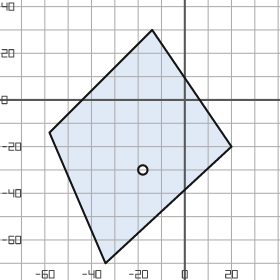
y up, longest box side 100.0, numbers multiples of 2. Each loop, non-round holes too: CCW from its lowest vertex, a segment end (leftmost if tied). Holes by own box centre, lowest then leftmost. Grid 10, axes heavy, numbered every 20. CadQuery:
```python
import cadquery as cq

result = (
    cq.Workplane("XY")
    .moveTo(-34.0, -70.0)
    .lineTo(20.0, -20.0)
    .lineTo(-14.0, 30.0)
    .lineTo(-58.0, -14.0)
    .close()
    .moveTo(-18.0, -30.0)
    .circle(2.0)
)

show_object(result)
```